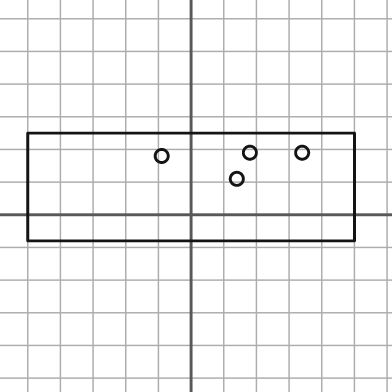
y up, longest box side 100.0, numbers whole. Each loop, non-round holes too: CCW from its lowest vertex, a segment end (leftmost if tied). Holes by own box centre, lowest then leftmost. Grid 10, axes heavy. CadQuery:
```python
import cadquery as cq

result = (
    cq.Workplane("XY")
    .moveTo(-50.0, -8.0)
    .lineTo(50.0, -8.0)
    .lineTo(50.0, 25.0)
    .lineTo(-50.0, 25.0)
    .close()
    .moveTo(14.0, 11.0)
    .circle(2.0)
    .moveTo(-9.0, 18.0)
    .circle(2.0)
    .moveTo(18.0, 19.0)
    .circle(2.0)
    .moveTo(34.0, 19.0)
    .circle(2.0)
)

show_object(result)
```